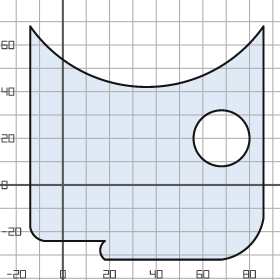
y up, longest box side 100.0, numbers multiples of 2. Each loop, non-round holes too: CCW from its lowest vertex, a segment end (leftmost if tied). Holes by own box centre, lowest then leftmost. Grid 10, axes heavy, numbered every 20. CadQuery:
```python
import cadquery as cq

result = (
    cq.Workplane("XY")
    .moveTo(18.0, -32.0)
    .lineTo(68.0, -32.0)
    .threePointArc((80.0, -26.0), (86.0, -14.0))
    .lineTo(86.0, 68.0)
    .threePointArc((36.0, 42.0), (-14.0, 68.0))
    .lineTo(-14.0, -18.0)
    .threePointArc((-12.0, -22.0), (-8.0, -24.0))
    .lineTo(18.0, -24.0)
    .threePointArc((16.0, -28.0), (18.0, -32.0))
    .close()
    .moveTo(68.0, 20.0)
    .circle(12.0)
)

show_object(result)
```